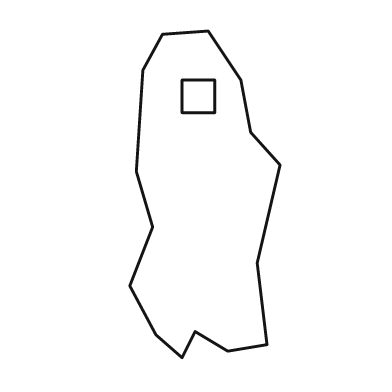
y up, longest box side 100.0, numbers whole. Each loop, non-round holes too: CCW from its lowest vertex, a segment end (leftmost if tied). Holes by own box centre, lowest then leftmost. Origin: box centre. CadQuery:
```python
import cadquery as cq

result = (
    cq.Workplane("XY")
    .moveTo(-7.0, -50.0)
    .lineTo(-3.0, -42.0)
    .lineTo(7.0, -48.0)
    .lineTo(19.0, -46.0)
    .lineTo(16.0, -21.0)
    .lineTo(23.0, 9.0)
    .lineTo(14.0, 19.0)
    .lineTo(11.0, 35.0)
    .lineTo(1.0, 50.0)
    .lineTo(-13.0, 49.0)
    .lineTo(-19.0, 38.0)
    .lineTo(-21.0, 7.0)
    .lineTo(-16.0, -10.0)
    .lineTo(-23.0, -28.0)
    .lineTo(-15.0, -43.0)
    .close()
    .moveTo(-7.0, 25.0)
    .lineTo(3.0, 25.0)
    .lineTo(3.0, 35.0)
    .lineTo(-7.0, 35.0)
    .close()
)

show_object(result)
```